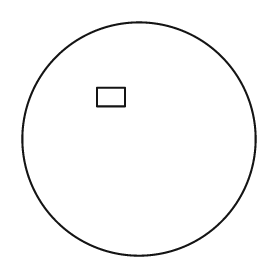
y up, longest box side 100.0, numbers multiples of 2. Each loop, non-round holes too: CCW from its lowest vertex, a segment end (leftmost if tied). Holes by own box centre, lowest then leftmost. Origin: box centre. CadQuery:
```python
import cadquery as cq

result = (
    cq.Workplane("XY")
    .moveTo(0.0, 0.0)
    .circle(50.0)
    .moveTo(-18.0, 14.0)
    .lineTo(-6.0, 14.0)
    .lineTo(-6.0, 22.0)
    .lineTo(-18.0, 22.0)
    .close()
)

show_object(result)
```